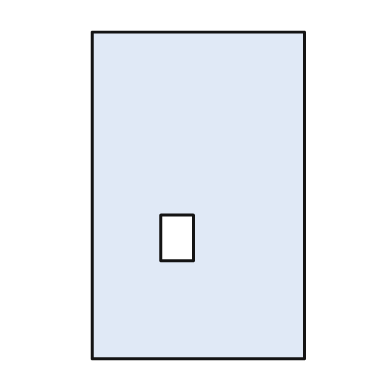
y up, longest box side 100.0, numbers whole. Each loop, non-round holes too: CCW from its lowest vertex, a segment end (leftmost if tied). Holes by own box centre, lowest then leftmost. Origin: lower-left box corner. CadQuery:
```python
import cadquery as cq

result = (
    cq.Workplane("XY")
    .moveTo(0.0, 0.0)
    .lineTo(65.0, 0.0)
    .lineTo(65.0, 100.0)
    .lineTo(0.0, 100.0)
    .close()
    .moveTo(21.0, 30.0)
    .lineTo(31.0, 30.0)
    .lineTo(31.0, 44.0)
    .lineTo(21.0, 44.0)
    .close()
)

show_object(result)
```